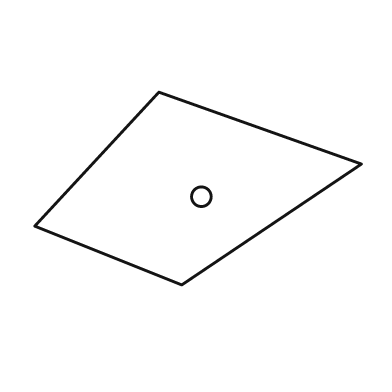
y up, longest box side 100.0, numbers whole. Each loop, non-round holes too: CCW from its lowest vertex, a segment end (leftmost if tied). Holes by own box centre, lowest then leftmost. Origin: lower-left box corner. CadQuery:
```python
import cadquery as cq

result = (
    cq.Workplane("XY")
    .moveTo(45.0, 0.0)
    .lineTo(100.0, 37.0)
    .lineTo(38.0, 59.0)
    .lineTo(0.0, 18.0)
    .close()
    .moveTo(51.0, 27.0)
    .circle(3.0)
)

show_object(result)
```